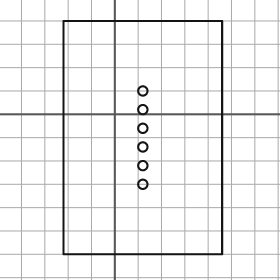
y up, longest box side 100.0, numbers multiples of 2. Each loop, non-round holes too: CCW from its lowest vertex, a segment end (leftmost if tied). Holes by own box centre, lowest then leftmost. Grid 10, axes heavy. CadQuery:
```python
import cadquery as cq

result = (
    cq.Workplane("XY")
    .moveTo(-22.0, -60.0)
    .lineTo(46.0, -60.0)
    .lineTo(46.0, 40.0)
    .lineTo(-22.0, 40.0)
    .close()
    .moveTo(12.0, -30.0)
    .circle(2.0)
    .moveTo(12.0, -22.0)
    .circle(2.0)
    .moveTo(12.0, -14.0)
    .circle(2.0)
    .moveTo(12.0, -6.0)
    .circle(2.0)
    .moveTo(12.0, 2.0)
    .circle(2.0)
    .moveTo(12.0, 10.0)
    .circle(2.0)
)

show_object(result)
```